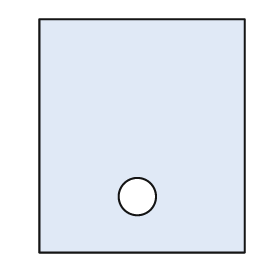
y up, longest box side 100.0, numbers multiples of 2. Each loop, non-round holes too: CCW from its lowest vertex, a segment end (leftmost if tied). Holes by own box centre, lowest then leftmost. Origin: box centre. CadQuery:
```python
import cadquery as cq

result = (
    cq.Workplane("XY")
    .moveTo(-44.0, -50.0)
    .lineTo(44.0, -50.0)
    .lineTo(44.0, 50.0)
    .lineTo(-44.0, 50.0)
    .close()
    .moveTo(-2.0, -26.0)
    .circle(8.0)
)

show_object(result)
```